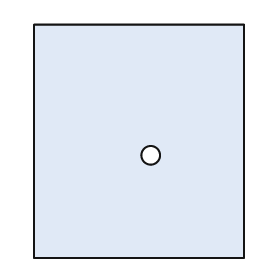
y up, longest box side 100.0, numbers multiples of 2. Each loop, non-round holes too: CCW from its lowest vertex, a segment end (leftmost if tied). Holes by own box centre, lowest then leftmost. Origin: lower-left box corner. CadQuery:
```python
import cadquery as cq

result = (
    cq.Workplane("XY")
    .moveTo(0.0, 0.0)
    .lineTo(90.0, 0.0)
    .lineTo(90.0, 100.0)
    .lineTo(0.0, 100.0)
    .close()
    .moveTo(50.0, 44.0)
    .circle(4.0)
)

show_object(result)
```